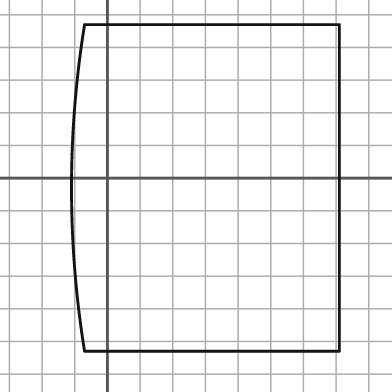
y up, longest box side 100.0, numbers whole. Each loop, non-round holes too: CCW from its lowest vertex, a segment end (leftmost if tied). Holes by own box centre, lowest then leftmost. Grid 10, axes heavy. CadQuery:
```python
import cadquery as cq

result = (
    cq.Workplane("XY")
    .moveTo(-7.0, -53.0)
    .lineTo(71.0, -53.0)
    .lineTo(71.0, 47.0)
    .lineTo(-7.0, 47.0)
    .threePointArc((-11.0, -3.0), (-7.0, -53.0))
    .close()
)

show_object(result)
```